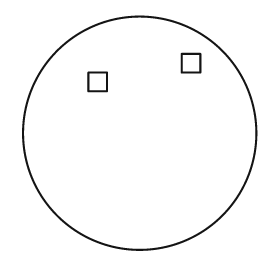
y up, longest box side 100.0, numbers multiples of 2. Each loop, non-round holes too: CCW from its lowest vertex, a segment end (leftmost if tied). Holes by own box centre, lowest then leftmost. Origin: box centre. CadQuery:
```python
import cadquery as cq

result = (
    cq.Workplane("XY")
    .moveTo(0.0, 0.0)
    .circle(50.0)
    .moveTo(-22.0, 18.0)
    .lineTo(-14.0, 18.0)
    .lineTo(-14.0, 26.0)
    .lineTo(-22.0, 26.0)
    .close()
    .moveTo(18.0, 26.0)
    .lineTo(26.0, 26.0)
    .lineTo(26.0, 34.0)
    .lineTo(18.0, 34.0)
    .close()
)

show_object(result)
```